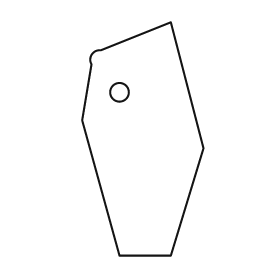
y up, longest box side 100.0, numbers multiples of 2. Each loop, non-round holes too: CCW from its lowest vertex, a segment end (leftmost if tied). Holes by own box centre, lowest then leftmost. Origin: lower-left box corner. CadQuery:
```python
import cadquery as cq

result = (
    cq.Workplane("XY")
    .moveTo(16.0, 0.0)
    .lineTo(38.0, 0.0)
    .lineTo(52.0, 46.0)
    .lineTo(38.0, 100.0)
    .lineTo(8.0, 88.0)
    .threePointArc((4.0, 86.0), (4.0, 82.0))
    .lineTo(0.0, 58.0)
    .close()
    .moveTo(16.0, 70.0)
    .circle(4.0)
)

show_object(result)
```